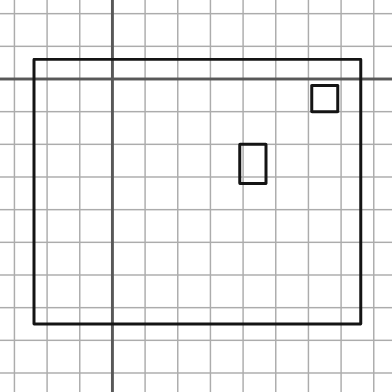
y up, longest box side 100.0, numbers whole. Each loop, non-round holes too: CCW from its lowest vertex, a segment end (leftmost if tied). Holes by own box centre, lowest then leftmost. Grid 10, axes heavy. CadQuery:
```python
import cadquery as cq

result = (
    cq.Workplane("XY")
    .moveTo(-24.0, -75.0)
    .lineTo(76.0, -75.0)
    .lineTo(76.0, 6.0)
    .lineTo(-24.0, 6.0)
    .close()
    .moveTo(39.0, -32.0)
    .lineTo(47.0, -32.0)
    .lineTo(47.0, -20.0)
    .lineTo(39.0, -20.0)
    .close()
    .moveTo(61.0, -10.0)
    .lineTo(69.0, -10.0)
    .lineTo(69.0, -2.0)
    .lineTo(61.0, -2.0)
    .close()
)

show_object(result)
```